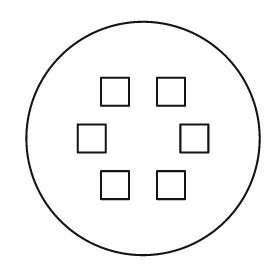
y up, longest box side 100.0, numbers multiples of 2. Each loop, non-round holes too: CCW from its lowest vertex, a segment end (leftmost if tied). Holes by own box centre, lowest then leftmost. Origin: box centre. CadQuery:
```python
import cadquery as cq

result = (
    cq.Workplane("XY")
    .moveTo(0.0, 0.0)
    .circle(50.0)
    .moveTo(-18.0, -26.0)
    .lineTo(-6.0, -26.0)
    .lineTo(-6.0, -14.0)
    .lineTo(-18.0, -14.0)
    .close()
    .moveTo(6.0, -26.0)
    .lineTo(18.0, -26.0)
    .lineTo(18.0, -14.0)
    .lineTo(6.0, -14.0)
    .close()
    .moveTo(-28.0, -6.0)
    .lineTo(-16.0, -6.0)
    .lineTo(-16.0, 6.0)
    .lineTo(-28.0, 6.0)
    .close()
    .moveTo(16.0, -6.0)
    .lineTo(28.0, -6.0)
    .lineTo(28.0, 6.0)
    .lineTo(16.0, 6.0)
    .close()
    .moveTo(-18.0, 14.0)
    .lineTo(-6.0, 14.0)
    .lineTo(-6.0, 26.0)
    .lineTo(-18.0, 26.0)
    .close()
    .moveTo(6.0, 14.0)
    .lineTo(18.0, 14.0)
    .lineTo(18.0, 26.0)
    .lineTo(6.0, 26.0)
    .close()
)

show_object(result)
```